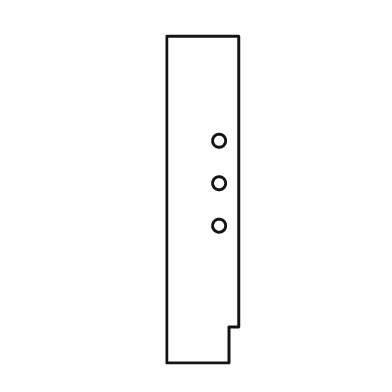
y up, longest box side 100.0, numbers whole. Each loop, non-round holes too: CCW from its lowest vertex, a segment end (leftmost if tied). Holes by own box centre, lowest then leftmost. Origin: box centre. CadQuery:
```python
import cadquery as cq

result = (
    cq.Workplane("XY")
    .moveTo(-11.0, -50.0)
    .lineTo(8.0, -50.0)
    .lineTo(8.0, -39.0)
    .lineTo(11.0, -39.0)
    .lineTo(11.0, 50.0)
    .lineTo(-11.0, 50.0)
    .close()
    .moveTo(5.0, -8.0)
    .circle(2.0)
    .moveTo(5.0, 5.0)
    .circle(2.0)
    .moveTo(5.0, 18.0)
    .circle(2.0)
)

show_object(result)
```